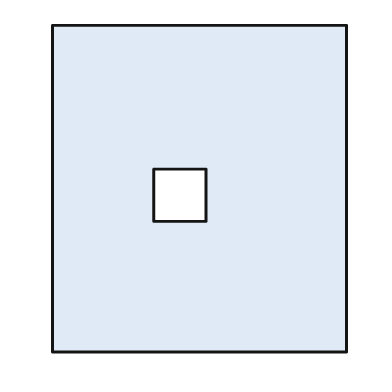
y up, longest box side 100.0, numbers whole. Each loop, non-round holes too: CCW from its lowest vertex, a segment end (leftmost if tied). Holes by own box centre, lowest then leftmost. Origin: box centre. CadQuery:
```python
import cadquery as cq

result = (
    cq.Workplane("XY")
    .moveTo(-45.0, -50.0)
    .lineTo(45.0, -50.0)
    .lineTo(45.0, 50.0)
    .lineTo(-45.0, 50.0)
    .close()
    .moveTo(-14.0, -10.0)
    .lineTo(2.0, -10.0)
    .lineTo(2.0, 6.0)
    .lineTo(-14.0, 6.0)
    .close()
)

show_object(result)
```